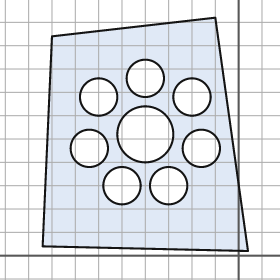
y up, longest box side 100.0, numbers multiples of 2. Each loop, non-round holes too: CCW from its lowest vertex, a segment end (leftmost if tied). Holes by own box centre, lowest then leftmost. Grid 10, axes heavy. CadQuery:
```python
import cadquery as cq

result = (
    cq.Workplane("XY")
    .moveTo(4.0, 2.0)
    .lineTo(-10.0, 102.0)
    .lineTo(-80.0, 94.0)
    .lineTo(-84.0, 4.0)
    .close()
    .moveTo(-50.0, 30.0)
    .circle(8.0)
    .moveTo(-30.0, 30.0)
    .circle(8.0)
    .moveTo(-64.0, 46.0)
    .circle(8.0)
    .moveTo(-16.0, 46.0)
    .circle(8.0)
    .moveTo(-40.0, 52.0)
    .circle(12.0)
    .moveTo(-60.0, 68.0)
    .circle(8.0)
    .moveTo(-20.0, 68.0)
    .circle(8.0)
    .moveTo(-40.0, 76.0)
    .circle(8.0)
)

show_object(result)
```